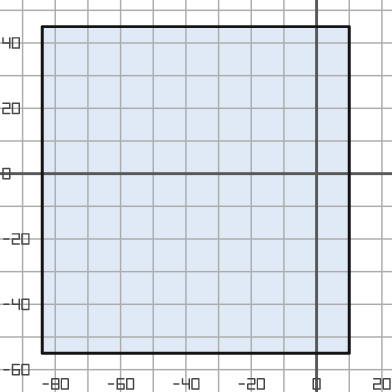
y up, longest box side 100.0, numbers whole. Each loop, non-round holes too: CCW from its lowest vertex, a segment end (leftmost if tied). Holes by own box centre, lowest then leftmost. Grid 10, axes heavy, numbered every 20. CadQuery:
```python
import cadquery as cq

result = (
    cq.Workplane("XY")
    .moveTo(-84.0, -55.0)
    .lineTo(10.0, -55.0)
    .lineTo(10.0, 45.0)
    .lineTo(-84.0, 45.0)
    .close()
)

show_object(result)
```